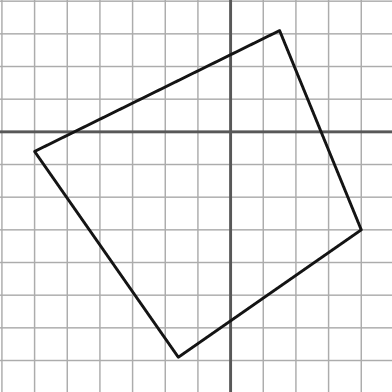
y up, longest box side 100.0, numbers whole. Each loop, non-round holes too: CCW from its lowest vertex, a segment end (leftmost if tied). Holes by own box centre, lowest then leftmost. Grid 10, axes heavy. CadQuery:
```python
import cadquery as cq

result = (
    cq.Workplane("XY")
    .moveTo(-16.0, -69.0)
    .lineTo(40.0, -30.0)
    .lineTo(15.0, 31.0)
    .lineTo(-60.0, -6.0)
    .close()
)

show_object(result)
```